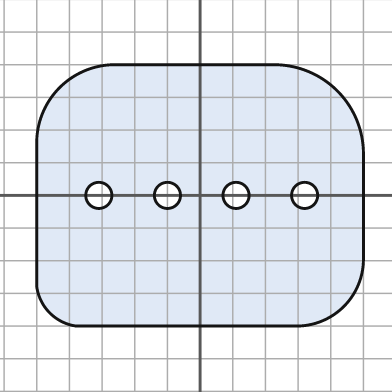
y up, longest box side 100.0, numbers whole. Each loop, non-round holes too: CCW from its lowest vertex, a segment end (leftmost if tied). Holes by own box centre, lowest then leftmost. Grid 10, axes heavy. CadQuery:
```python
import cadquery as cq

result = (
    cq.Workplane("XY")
    .moveTo(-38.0, -40.0)
    .lineTo(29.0, -40.0)
    .threePointArc((44.0, -34.0), (50.0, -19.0))
    .lineTo(50.0, 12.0)
    .threePointArc((42.0, 32.0), (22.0, 40.0))
    .lineTo(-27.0, 40.0)
    .threePointArc((-43.0, 33.0), (-50.0, 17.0))
    .lineTo(-50.0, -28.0)
    .threePointArc((-46.0, -36.0), (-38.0, -40.0))
    .close()
    .moveTo(-31.0, 0.0)
    .circle(4.0)
    .moveTo(-10.0, 0.0)
    .circle(4.0)
    .moveTo(11.0, 0.0)
    .circle(4.0)
    .moveTo(32.0, 0.0)
    .circle(4.0)
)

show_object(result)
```